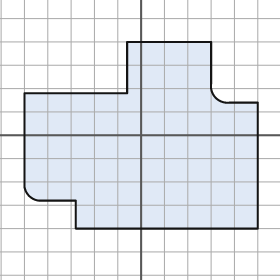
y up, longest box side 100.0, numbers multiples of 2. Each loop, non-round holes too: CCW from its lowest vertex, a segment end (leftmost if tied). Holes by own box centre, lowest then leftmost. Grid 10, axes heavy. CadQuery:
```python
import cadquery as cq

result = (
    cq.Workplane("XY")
    .moveTo(-28.0, -40.0)
    .lineTo(50.0, -40.0)
    .lineTo(50.0, 14.0)
    .lineTo(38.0, 14.0)
    .threePointArc((32.0, 16.0), (30.0, 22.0))
    .lineTo(30.0, 40.0)
    .lineTo(-6.0, 40.0)
    .lineTo(-6.0, 18.0)
    .lineTo(-50.0, 18.0)
    .lineTo(-50.0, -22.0)
    .threePointArc((-48.0, -26.0), (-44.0, -28.0))
    .lineTo(-28.0, -28.0)
    .close()
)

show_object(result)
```